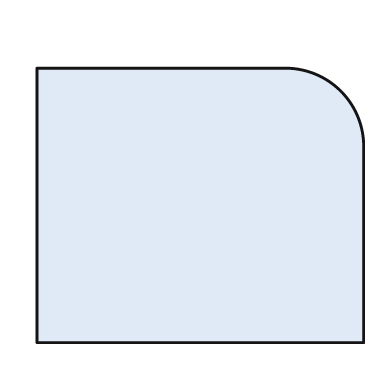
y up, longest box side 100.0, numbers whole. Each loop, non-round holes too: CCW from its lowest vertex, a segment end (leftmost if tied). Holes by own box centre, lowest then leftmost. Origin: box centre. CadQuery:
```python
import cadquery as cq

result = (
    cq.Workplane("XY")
    .moveTo(-50.0, -42.0)
    .lineTo(50.0, -42.0)
    .lineTo(50.0, 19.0)
    .threePointArc((43.0, 35.0), (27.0, 42.0))
    .lineTo(-50.0, 42.0)
    .close()
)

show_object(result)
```